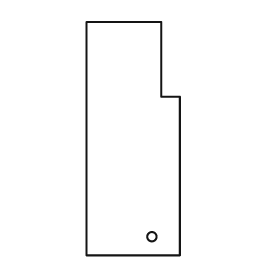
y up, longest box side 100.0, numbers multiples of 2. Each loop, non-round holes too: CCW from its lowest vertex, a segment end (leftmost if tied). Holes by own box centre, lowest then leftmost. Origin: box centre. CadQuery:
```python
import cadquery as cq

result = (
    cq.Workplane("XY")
    .moveTo(-20.0, -50.0)
    .lineTo(20.0, -50.0)
    .lineTo(20.0, 18.0)
    .lineTo(12.0, 18.0)
    .lineTo(12.0, 50.0)
    .lineTo(-20.0, 50.0)
    .close()
    .moveTo(8.0, -42.0)
    .circle(2.0)
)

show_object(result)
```